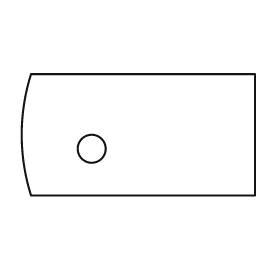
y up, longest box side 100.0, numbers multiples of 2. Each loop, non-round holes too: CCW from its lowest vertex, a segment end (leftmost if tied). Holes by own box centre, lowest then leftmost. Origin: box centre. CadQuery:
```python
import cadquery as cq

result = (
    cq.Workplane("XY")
    .moveTo(-46.0, -26.0)
    .lineTo(50.0, -26.0)
    .lineTo(50.0, 26.0)
    .lineTo(-46.0, 26.0)
    .threePointArc((-50.0, 0.0), (-46.0, -26.0))
    .close()
    .moveTo(-20.0, -6.0)
    .circle(6.0)
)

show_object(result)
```